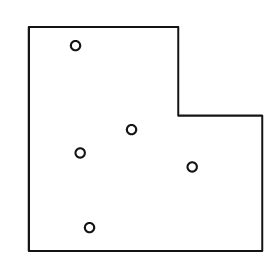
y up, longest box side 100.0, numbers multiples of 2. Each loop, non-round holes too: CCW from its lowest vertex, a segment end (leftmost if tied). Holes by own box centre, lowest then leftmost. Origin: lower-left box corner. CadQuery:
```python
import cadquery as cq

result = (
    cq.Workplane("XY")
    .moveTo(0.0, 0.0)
    .lineTo(100.0, 0.0)
    .lineTo(100.0, 58.0)
    .lineTo(64.0, 58.0)
    .lineTo(64.0, 96.0)
    .lineTo(0.0, 96.0)
    .close()
    .moveTo(26.0, 10.0)
    .circle(2.0)
    .moveTo(70.0, 36.0)
    .circle(2.0)
    .moveTo(22.0, 42.0)
    .circle(2.0)
    .moveTo(44.0, 52.0)
    .circle(2.0)
    .moveTo(20.0, 88.0)
    .circle(2.0)
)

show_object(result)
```